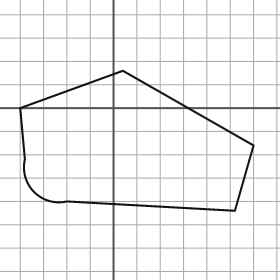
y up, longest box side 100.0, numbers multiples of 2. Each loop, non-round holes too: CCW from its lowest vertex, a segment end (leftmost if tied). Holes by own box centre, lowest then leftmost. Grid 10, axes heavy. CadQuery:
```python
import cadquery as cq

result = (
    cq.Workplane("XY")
    .moveTo(52.0, -44.0)
    .lineTo(60.0, -16.0)
    .lineTo(4.0, 16.0)
    .lineTo(-40.0, 0.0)
    .lineTo(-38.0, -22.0)
    .threePointArc((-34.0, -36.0), (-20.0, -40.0))
    .close()
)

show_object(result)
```